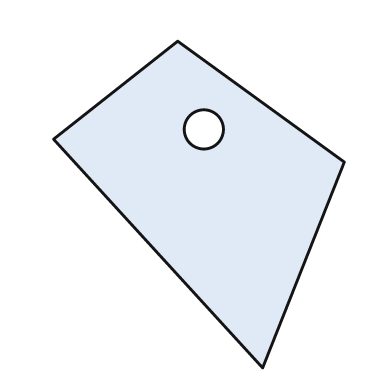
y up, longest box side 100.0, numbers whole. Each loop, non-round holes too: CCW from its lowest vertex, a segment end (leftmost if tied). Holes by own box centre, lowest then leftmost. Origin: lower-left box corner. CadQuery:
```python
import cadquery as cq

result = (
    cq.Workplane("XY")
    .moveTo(64.0, 0.0)
    .lineTo(89.0, 63.0)
    .lineTo(38.0, 100.0)
    .lineTo(0.0, 70.0)
    .close()
    .moveTo(46.0, 73.0)
    .circle(6.0)
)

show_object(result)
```